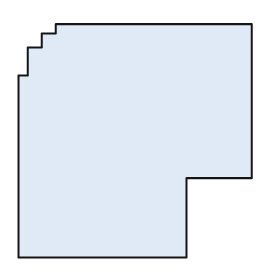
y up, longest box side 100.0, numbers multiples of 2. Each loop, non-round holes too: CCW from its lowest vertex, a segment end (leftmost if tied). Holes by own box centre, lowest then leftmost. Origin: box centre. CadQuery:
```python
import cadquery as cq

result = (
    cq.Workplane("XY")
    .moveTo(-50.0, -50.0)
    .lineTo(22.0, -50.0)
    .lineTo(22.0, -16.0)
    .lineTo(50.0, -16.0)
    .lineTo(50.0, 50.0)
    .lineTo(-34.0, 50.0)
    .lineTo(-34.0, 46.0)
    .lineTo(-40.0, 46.0)
    .lineTo(-40.0, 40.0)
    .lineTo(-46.0, 40.0)
    .lineTo(-46.0, 28.0)
    .lineTo(-50.0, 28.0)
    .close()
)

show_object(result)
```